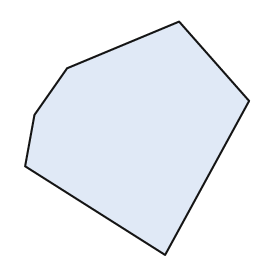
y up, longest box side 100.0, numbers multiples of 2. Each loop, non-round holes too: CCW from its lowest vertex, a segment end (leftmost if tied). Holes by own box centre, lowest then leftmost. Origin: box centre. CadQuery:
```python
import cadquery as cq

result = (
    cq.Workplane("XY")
    .moveTo(12.0, -50.0)
    .lineTo(48.0, 16.0)
    .lineTo(18.0, 50.0)
    .lineTo(-30.0, 30.0)
    .lineTo(-44.0, 10.0)
    .lineTo(-48.0, -12.0)
    .close()
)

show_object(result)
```